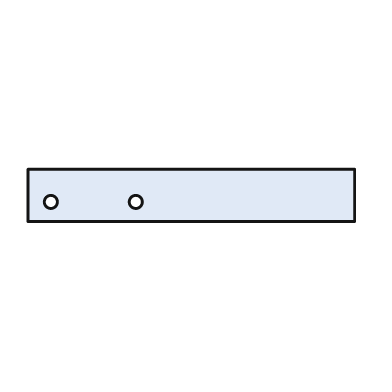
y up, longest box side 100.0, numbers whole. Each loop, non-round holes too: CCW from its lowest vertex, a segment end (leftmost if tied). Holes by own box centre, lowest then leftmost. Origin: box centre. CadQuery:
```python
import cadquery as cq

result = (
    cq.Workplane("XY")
    .moveTo(-50.0, -8.0)
    .lineTo(50.0, -8.0)
    .lineTo(50.0, 8.0)
    .lineTo(-50.0, 8.0)
    .close()
    .moveTo(-43.0, -2.0)
    .circle(2.0)
    .moveTo(-17.0, -2.0)
    .circle(2.0)
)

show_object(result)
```